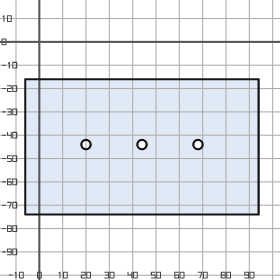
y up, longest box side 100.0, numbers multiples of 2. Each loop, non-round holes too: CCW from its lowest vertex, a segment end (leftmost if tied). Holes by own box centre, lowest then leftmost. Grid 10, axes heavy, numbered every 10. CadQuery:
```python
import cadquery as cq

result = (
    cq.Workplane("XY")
    .moveTo(-6.0, -74.0)
    .lineTo(94.0, -74.0)
    .lineTo(94.0, -16.0)
    .lineTo(-6.0, -16.0)
    .close()
    .moveTo(20.0, -44.0)
    .circle(2.0)
    .moveTo(44.0, -44.0)
    .circle(2.0)
    .moveTo(68.0, -44.0)
    .circle(2.0)
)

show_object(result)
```